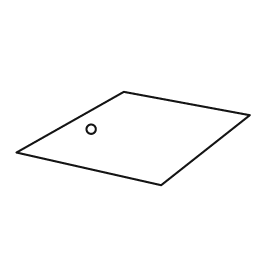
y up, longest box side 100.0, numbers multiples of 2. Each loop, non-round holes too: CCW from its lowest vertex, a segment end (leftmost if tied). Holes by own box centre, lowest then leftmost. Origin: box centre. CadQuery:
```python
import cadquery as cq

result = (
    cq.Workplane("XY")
    .moveTo(12.0, -20.0)
    .lineTo(50.0, 10.0)
    .lineTo(-4.0, 20.0)
    .lineTo(-50.0, -6.0)
    .close()
    .moveTo(-18.0, 4.0)
    .circle(2.0)
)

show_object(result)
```